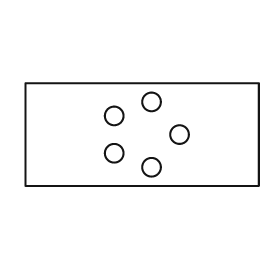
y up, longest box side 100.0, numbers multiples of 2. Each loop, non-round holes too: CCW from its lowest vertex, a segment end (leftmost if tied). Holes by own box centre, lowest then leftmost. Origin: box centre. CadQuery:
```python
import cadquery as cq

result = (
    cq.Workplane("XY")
    .moveTo(-50.0, -22.0)
    .lineTo(50.0, -22.0)
    .lineTo(50.0, 22.0)
    .lineTo(-50.0, 22.0)
    .close()
    .moveTo(4.0, -14.0)
    .circle(4.0)
    .moveTo(-12.0, -8.0)
    .circle(4.0)
    .moveTo(16.0, 0.0)
    .circle(4.0)
    .moveTo(-12.0, 8.0)
    .circle(4.0)
    .moveTo(4.0, 14.0)
    .circle(4.0)
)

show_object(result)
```